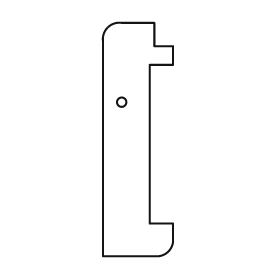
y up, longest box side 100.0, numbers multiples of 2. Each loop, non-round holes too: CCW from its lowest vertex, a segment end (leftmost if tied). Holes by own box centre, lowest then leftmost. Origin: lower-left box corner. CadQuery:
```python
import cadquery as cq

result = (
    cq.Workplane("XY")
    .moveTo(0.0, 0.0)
    .lineTo(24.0, 0.0)
    .threePointArc((28.0, 2.0), (30.0, 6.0))
    .lineTo(30.0, 14.0)
    .lineTo(20.0, 14.0)
    .lineTo(20.0, 82.0)
    .lineTo(30.0, 82.0)
    .lineTo(30.0, 90.0)
    .lineTo(22.0, 90.0)
    .lineTo(22.0, 100.0)
    .lineTo(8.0, 100.0)
    .threePointArc((2.0, 98.0), (0.0, 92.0))
    .close()
    .moveTo(8.0, 66.0)
    .circle(2.0)
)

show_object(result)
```